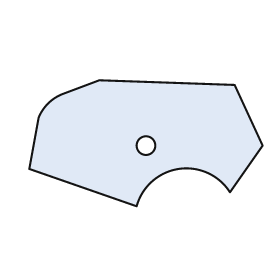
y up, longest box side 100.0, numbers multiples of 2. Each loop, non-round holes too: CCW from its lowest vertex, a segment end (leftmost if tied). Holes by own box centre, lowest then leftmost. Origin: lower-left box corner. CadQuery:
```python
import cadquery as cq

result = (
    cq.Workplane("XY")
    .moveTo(46.0, 0.0)
    .threePointArc((64.0, 16.0), (86.0, 6.0))
    .lineTo(100.0, 26.0)
    .lineTo(88.0, 52.0)
    .lineTo(30.0, 54.0)
    .lineTo(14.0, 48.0)
    .threePointArc((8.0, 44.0), (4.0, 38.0))
    .lineTo(0.0, 16.0)
    .close()
    .moveTo(50.0, 26.0)
    .circle(4.0)
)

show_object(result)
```